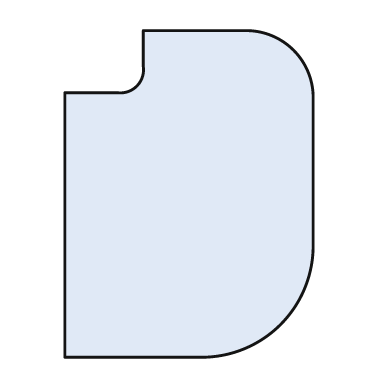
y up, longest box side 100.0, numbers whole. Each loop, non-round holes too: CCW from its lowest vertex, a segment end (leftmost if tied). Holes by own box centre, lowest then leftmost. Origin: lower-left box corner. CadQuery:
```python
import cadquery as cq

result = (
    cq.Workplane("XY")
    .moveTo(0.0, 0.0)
    .lineTo(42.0, 0.0)
    .threePointArc((66.0, 10.0), (76.0, 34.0))
    .lineTo(76.0, 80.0)
    .threePointArc((70.0, 94.0), (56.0, 100.0))
    .lineTo(24.0, 100.0)
    .lineTo(24.0, 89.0)
    .threePointArc((22.0, 83.0), (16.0, 81.0))
    .lineTo(0.0, 81.0)
    .close()
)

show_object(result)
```